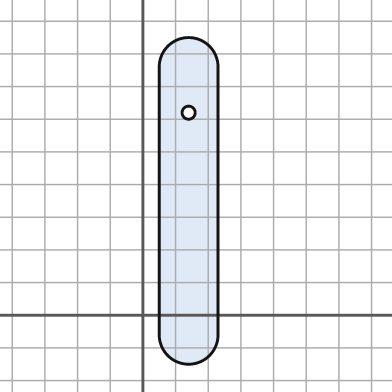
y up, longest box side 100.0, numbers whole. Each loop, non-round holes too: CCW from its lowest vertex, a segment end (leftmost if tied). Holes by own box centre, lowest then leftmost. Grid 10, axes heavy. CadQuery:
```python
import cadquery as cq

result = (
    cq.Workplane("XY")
    .moveTo(5.0, -6.0)
    .threePointArc((14.0, -15.0), (23.0, -6.0))
    .lineTo(23.0, 76.0)
    .threePointArc((14.0, 85.0), (5.0, 76.0))
    .close()
    .moveTo(14.0, 62.0)
    .circle(2.0)
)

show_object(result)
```